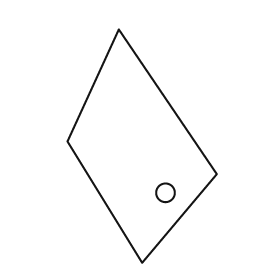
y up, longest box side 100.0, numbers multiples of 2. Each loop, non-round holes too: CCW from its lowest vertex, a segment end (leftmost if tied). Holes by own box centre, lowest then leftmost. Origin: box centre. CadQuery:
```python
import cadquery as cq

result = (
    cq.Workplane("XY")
    .moveTo(0.0, -50.0)
    .lineTo(32.0, -12.0)
    .lineTo(-10.0, 50.0)
    .lineTo(-32.0, 2.0)
    .close()
    .moveTo(10.0, -20.0)
    .circle(4.0)
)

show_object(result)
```